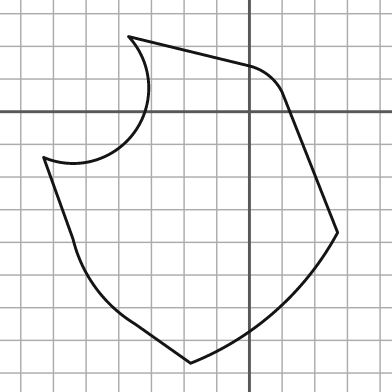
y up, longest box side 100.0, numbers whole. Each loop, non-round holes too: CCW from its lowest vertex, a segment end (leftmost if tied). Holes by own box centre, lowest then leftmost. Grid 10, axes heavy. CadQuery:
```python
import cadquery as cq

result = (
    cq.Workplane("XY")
    .moveTo(-18.0, -77.0)
    .threePointArc((8.0, -61.0), (27.0, -37.0))
    .lineTo(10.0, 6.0)
    .threePointArc((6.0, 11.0), (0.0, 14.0))
    .lineTo(-37.0, 23.0)
    .threePointArc((-35.0, -6.0), (-63.0, -14.0))
    .lineTo(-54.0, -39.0)
    .threePointArc((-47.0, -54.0), (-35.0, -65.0))
    .close()
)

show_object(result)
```